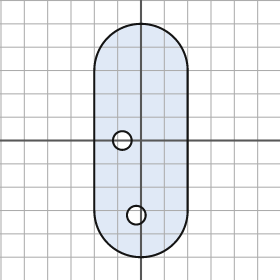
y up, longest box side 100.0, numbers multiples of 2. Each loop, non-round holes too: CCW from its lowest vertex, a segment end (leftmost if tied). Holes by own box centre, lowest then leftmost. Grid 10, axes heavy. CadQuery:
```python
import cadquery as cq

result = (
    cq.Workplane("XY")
    .moveTo(-20.0, -30.0)
    .threePointArc((0.0, -50.0), (20.0, -30.0))
    .lineTo(20.0, 30.0)
    .threePointArc((0.0, 50.0), (-20.0, 30.0))
    .close()
    .moveTo(-2.0, -32.0)
    .circle(4.0)
    .moveTo(-8.0, 0.0)
    .circle(4.0)
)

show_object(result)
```